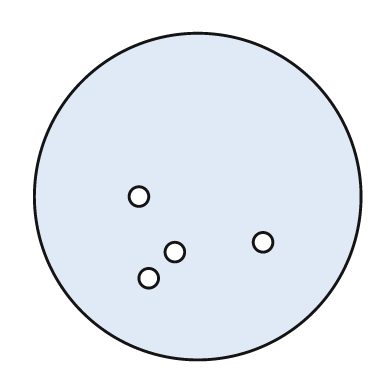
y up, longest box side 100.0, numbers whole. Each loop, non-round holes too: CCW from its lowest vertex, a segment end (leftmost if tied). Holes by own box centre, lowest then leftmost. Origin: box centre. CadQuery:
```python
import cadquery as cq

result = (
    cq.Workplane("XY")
    .moveTo(0.0, 0.0)
    .circle(50.0)
    .moveTo(-15.0, -25.0)
    .circle(3.0)
    .moveTo(-7.0, -17.0)
    .circle(3.0)
    .moveTo(20.0, -14.0)
    .circle(3.0)
    .moveTo(-18.0, 0.0)
    .circle(3.0)
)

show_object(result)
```